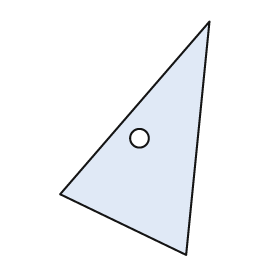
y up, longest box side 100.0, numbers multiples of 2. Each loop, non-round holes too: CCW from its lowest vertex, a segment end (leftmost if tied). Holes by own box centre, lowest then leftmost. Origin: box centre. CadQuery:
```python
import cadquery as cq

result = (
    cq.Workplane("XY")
    .moveTo(22.0, -50.0)
    .lineTo(32.0, 50.0)
    .lineTo(-32.0, -24.0)
    .close()
    .moveTo(2.0, 0.0)
    .circle(4.0)
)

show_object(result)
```